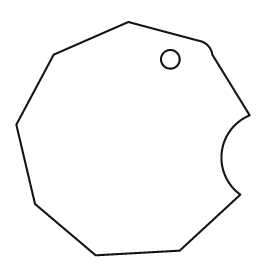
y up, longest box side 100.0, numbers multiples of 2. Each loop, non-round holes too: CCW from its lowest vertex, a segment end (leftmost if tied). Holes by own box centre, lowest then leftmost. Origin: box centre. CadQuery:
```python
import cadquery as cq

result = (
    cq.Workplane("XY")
    .moveTo(-16.0, -50.0)
    .lineTo(20.0, -48.0)
    .lineTo(46.0, -24.0)
    .threePointArc((38.0, -6.0), (50.0, 10.0))
    .lineTo(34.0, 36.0)
    .threePointArc((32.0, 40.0), (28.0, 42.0))
    .lineTo(-2.0, 50.0)
    .lineTo(-34.0, 36.0)
    .lineTo(-50.0, 6.0)
    .lineTo(-42.0, -28.0)
    .close()
    .moveTo(16.0, 34.0)
    .circle(4.0)
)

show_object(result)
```